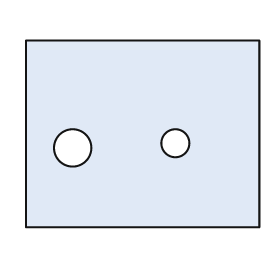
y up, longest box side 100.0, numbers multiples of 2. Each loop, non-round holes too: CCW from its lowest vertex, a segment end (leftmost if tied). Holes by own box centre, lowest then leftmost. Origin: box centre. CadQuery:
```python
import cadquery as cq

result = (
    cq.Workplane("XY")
    .moveTo(-50.0, -40.0)
    .lineTo(50.0, -40.0)
    .lineTo(50.0, 40.0)
    .lineTo(-50.0, 40.0)
    .close()
    .moveTo(-30.0, -6.0)
    .circle(8.0)
    .moveTo(14.0, -4.0)
    .circle(6.0)
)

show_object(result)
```